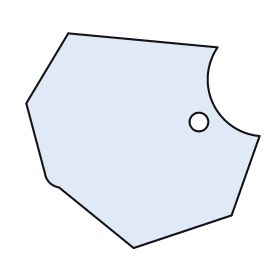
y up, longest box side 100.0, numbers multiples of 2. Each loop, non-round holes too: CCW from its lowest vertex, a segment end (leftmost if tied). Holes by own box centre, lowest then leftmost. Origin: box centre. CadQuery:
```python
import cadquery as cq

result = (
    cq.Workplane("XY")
    .moveTo(-4.0, -46.0)
    .lineTo(38.0, -32.0)
    .lineTo(50.0, 2.0)
    .threePointArc((30.0, 16.0), (32.0, 40.0))
    .lineTo(-32.0, 46.0)
    .lineTo(-50.0, 16.0)
    .lineTo(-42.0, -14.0)
    .threePointArc((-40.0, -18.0), (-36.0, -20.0))
    .close()
    .moveTo(24.0, 8.0)
    .circle(4.0)
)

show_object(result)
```